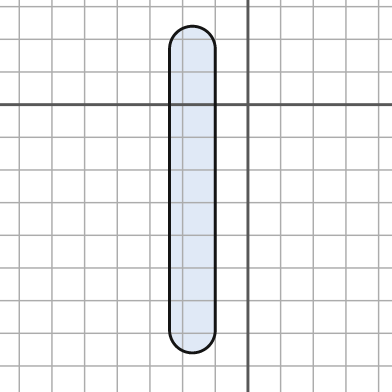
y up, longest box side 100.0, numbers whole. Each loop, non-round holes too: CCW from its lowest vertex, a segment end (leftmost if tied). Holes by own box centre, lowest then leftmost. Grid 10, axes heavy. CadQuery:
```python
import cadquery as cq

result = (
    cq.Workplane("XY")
    .moveTo(-24.0, -69.0)
    .threePointArc((-17.0, -76.0), (-10.0, -69.0))
    .lineTo(-10.0, 17.0)
    .threePointArc((-17.0, 24.0), (-24.0, 17.0))
    .close()
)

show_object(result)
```